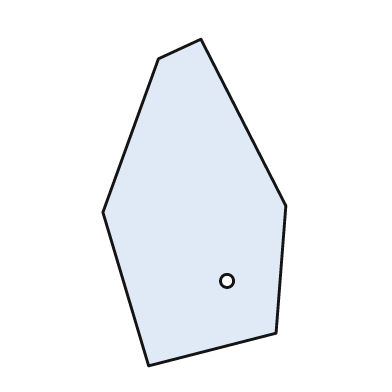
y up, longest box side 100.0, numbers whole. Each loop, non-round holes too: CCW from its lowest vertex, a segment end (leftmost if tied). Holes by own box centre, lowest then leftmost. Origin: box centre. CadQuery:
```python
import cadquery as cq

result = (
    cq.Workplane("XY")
    .moveTo(-14.0, -50.0)
    .lineTo(25.0, -40.0)
    .lineTo(28.0, -1.0)
    .lineTo(2.0, 50.0)
    .lineTo(-11.0, 44.0)
    .lineTo(-28.0, -3.0)
    .close()
    .moveTo(10.0, -24.0)
    .circle(2.0)
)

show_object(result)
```